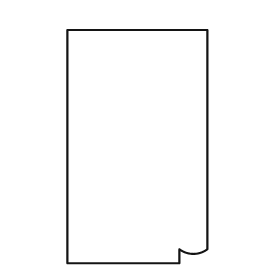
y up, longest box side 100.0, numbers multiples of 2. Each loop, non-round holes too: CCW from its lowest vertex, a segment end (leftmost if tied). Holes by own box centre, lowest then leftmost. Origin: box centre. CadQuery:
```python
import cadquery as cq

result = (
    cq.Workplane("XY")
    .moveTo(-30.0, -50.0)
    .lineTo(18.0, -50.0)
    .lineTo(18.0, -44.0)
    .threePointArc((24.0, -46.0), (30.0, -44.0))
    .lineTo(30.0, 50.0)
    .lineTo(-30.0, 50.0)
    .close()
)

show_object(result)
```